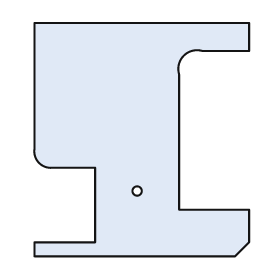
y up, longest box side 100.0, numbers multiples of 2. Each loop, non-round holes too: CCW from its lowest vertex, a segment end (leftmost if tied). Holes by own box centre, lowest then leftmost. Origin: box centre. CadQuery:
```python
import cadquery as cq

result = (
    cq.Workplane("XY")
    .moveTo(-46.0, -50.0)
    .lineTo(40.0, -50.0)
    .lineTo(46.0, -44.0)
    .lineTo(46.0, -30.0)
    .lineTo(16.0, -30.0)
    .lineTo(16.0, 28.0)
    .threePointArc((18.0, 36.0), (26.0, 38.0))
    .lineTo(46.0, 38.0)
    .lineTo(46.0, 50.0)
    .lineTo(-46.0, 50.0)
    .lineTo(-46.0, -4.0)
    .threePointArc((-44.0, -10.0), (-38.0, -12.0))
    .lineTo(-20.0, -12.0)
    .lineTo(-20.0, -44.0)
    .lineTo(-46.0, -44.0)
    .close()
    .moveTo(-2.0, -22.0)
    .circle(2.0)
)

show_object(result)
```